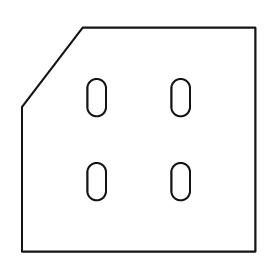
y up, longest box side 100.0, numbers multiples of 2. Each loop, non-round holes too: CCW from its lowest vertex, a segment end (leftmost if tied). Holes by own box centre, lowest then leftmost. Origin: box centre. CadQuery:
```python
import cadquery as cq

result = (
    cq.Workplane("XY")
    .moveTo(-50.0, -48.0)
    .lineTo(50.0, -48.0)
    .lineTo(50.0, 48.0)
    .lineTo(-24.0, 48.0)
    .lineTo(-50.0, 14.0)
    .close()
    .moveTo(-22.0, -22.0)
    .threePointArc((-18.0, -26.0), (-14.0, -22.0))
    .lineTo(-14.0, -14.0)
    .threePointArc((-18.0, -10.0), (-22.0, -14.0))
    .close()
    .moveTo(14.0, -22.0)
    .threePointArc((18.0, -26.0), (22.0, -22.0))
    .lineTo(22.0, -14.0)
    .threePointArc((18.0, -10.0), (14.0, -14.0))
    .close()
    .moveTo(-22.0, 14.0)
    .threePointArc((-18.0, 10.0), (-14.0, 14.0))
    .lineTo(-14.0, 22.0)
    .threePointArc((-18.0, 26.0), (-22.0, 22.0))
    .close()
    .moveTo(14.0, 14.0)
    .threePointArc((18.0, 10.0), (22.0, 14.0))
    .lineTo(22.0, 22.0)
    .threePointArc((18.0, 26.0), (14.0, 22.0))
    .close()
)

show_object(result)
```